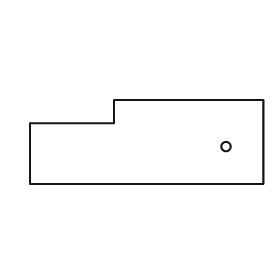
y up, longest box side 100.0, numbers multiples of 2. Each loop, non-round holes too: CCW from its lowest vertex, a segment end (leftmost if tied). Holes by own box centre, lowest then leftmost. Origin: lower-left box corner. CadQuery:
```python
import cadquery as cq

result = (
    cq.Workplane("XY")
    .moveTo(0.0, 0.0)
    .lineTo(100.0, 0.0)
    .lineTo(100.0, 36.0)
    .lineTo(36.0, 36.0)
    .lineTo(36.0, 26.0)
    .lineTo(0.0, 26.0)
    .close()
    .moveTo(84.0, 16.0)
    .circle(2.0)
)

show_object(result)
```